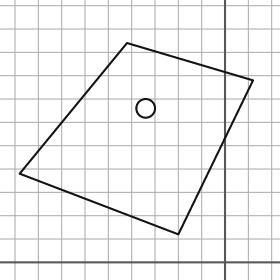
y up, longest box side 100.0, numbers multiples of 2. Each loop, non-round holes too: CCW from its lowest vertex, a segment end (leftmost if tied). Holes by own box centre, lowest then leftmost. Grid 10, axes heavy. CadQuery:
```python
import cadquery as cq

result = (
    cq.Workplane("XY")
    .moveTo(-20.0, 12.0)
    .lineTo(12.0, 78.0)
    .lineTo(-42.0, 94.0)
    .lineTo(-88.0, 38.0)
    .close()
    .moveTo(-34.0, 66.0)
    .circle(4.0)
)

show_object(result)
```